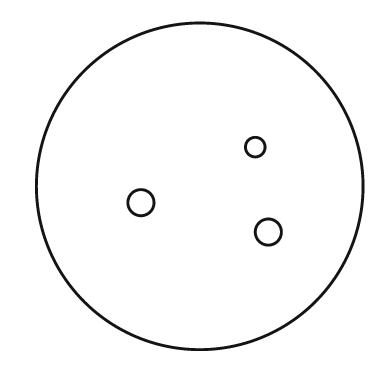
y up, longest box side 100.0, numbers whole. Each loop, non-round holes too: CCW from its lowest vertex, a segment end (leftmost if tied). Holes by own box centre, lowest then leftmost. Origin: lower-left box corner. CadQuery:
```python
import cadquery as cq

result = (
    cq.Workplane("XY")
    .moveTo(50.0, 50.0)
    .circle(50.0)
    .moveTo(71.0, 36.0)
    .circle(4.0)
    .moveTo(32.0, 45.0)
    .circle(4.0)
    .moveTo(67.0, 62.0)
    .circle(3.0)
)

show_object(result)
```